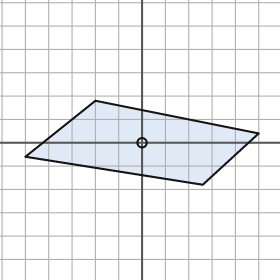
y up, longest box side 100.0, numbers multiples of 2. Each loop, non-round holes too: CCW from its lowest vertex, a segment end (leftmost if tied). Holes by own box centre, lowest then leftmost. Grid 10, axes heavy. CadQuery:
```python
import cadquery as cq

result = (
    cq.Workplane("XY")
    .moveTo(26.0, -18.0)
    .lineTo(50.0, 4.0)
    .lineTo(-20.0, 18.0)
    .lineTo(-50.0, -6.0)
    .close()
    .moveTo(0.0, 0.0)
    .circle(2.0)
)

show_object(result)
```